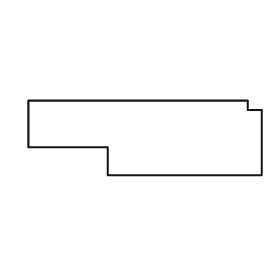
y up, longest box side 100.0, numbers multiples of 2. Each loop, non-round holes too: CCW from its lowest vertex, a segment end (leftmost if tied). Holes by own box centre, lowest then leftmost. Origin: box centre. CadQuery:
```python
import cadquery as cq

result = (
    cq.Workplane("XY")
    .moveTo(-16.0, -16.0)
    .lineTo(50.0, -16.0)
    .lineTo(50.0, 12.0)
    .lineTo(44.0, 12.0)
    .lineTo(44.0, 16.0)
    .lineTo(-50.0, 16.0)
    .lineTo(-50.0, -4.0)
    .lineTo(-16.0, -4.0)
    .close()
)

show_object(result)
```